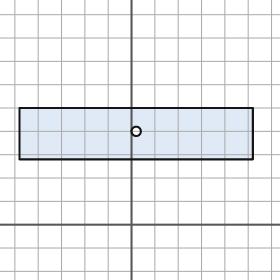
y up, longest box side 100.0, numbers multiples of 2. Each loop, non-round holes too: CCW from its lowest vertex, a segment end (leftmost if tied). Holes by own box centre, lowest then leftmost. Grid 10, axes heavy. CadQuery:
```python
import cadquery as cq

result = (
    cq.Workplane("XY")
    .moveTo(-48.0, 28.0)
    .lineTo(52.0, 28.0)
    .lineTo(52.0, 50.0)
    .lineTo(-48.0, 50.0)
    .close()
    .moveTo(2.0, 40.0)
    .circle(2.0)
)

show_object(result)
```